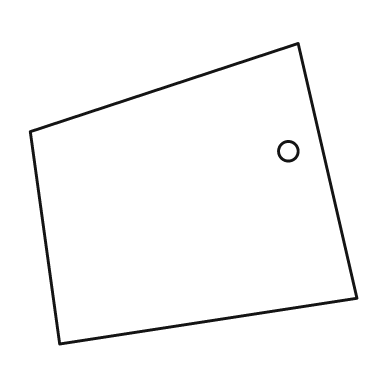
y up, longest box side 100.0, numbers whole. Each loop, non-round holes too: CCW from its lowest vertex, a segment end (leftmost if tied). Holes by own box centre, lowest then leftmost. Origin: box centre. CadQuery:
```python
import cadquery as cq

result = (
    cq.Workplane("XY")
    .moveTo(-41.0, -46.0)
    .lineTo(50.0, -32.0)
    .lineTo(32.0, 46.0)
    .lineTo(-50.0, 19.0)
    .close()
    .moveTo(29.0, 13.0)
    .circle(3.0)
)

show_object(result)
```